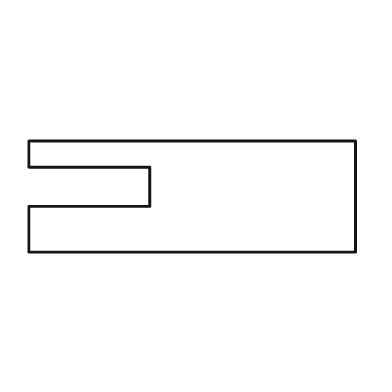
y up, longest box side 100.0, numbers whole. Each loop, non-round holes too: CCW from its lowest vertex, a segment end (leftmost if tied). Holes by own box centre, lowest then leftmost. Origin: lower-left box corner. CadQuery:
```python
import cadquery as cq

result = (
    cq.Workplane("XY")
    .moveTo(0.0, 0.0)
    .lineTo(100.0, 0.0)
    .lineTo(100.0, 34.0)
    .lineTo(0.0, 34.0)
    .lineTo(0.0, 26.0)
    .lineTo(37.0, 26.0)
    .lineTo(37.0, 14.0)
    .lineTo(0.0, 14.0)
    .close()
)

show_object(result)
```